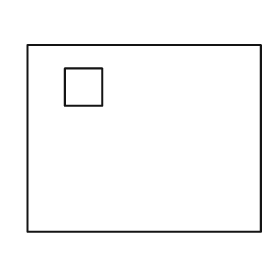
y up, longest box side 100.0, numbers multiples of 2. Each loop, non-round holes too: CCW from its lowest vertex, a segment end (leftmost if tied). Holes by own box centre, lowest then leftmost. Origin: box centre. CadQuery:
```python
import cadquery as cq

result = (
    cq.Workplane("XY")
    .moveTo(-50.0, -40.0)
    .lineTo(50.0, -40.0)
    .lineTo(50.0, 40.0)
    .lineTo(-50.0, 40.0)
    .close()
    .moveTo(-34.0, 14.0)
    .lineTo(-18.0, 14.0)
    .lineTo(-18.0, 30.0)
    .lineTo(-34.0, 30.0)
    .close()
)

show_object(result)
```